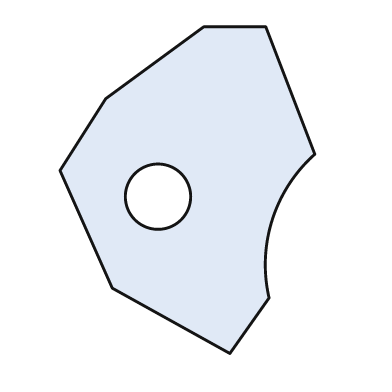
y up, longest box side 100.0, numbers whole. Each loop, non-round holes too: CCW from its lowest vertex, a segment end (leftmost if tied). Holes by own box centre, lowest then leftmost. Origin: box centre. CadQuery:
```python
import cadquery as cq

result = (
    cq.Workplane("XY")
    .moveTo(13.0, -50.0)
    .lineTo(25.0, -33.0)
    .threePointArc((26.0, -9.0), (39.0, 11.0))
    .lineTo(24.0, 50.0)
    .lineTo(5.0, 50.0)
    .lineTo(-25.0, 28.0)
    .lineTo(-39.0, 6.0)
    .lineTo(-23.0, -30.0)
    .close()
    .moveTo(-9.0, -2.0)
    .circle(10.0)
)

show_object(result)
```